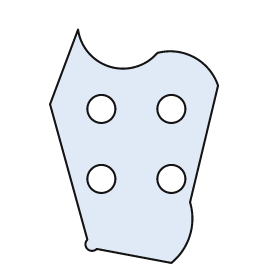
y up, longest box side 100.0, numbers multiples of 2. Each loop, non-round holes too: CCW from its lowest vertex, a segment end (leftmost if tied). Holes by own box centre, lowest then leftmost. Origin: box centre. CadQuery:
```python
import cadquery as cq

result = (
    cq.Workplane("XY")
    .moveTo(16.0, -50.0)
    .threePointArc((24.0, -38.0), (24.0, -24.0))
    .lineTo(36.0, 26.0)
    .threePointArc((26.0, 38.0), (10.0, 40.0))
    .threePointArc((-10.0, 34.0), (-24.0, 50.0))
    .lineTo(-36.0, 18.0)
    .lineTo(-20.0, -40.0)
    .threePointArc((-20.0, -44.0), (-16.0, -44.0))
    .close()
    .moveTo(-14.0, -14.0)
    .circle(6.0)
    .moveTo(16.0, -14.0)
    .circle(6.0)
    .moveTo(-14.0, 16.0)
    .circle(6.0)
    .moveTo(16.0, 16.0)
    .circle(6.0)
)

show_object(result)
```